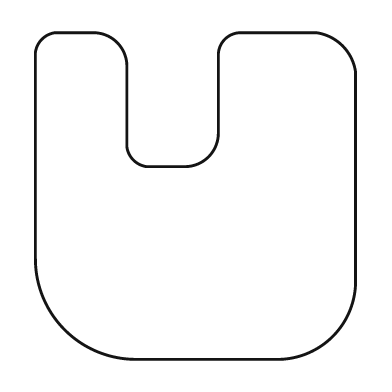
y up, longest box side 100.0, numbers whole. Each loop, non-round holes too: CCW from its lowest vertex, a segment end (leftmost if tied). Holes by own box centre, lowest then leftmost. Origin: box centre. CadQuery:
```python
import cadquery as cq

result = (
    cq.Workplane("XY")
    .moveTo(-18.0, -50.0)
    .lineTo(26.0, -50.0)
    .threePointArc((42.0, -43.0), (49.0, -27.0))
    .lineTo(49.0, 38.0)
    .threePointArc((45.0, 46.0), (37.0, 50.0))
    .lineTo(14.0, 50.0)
    .threePointArc((9.0, 48.0), (7.0, 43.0))
    .lineTo(7.0, 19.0)
    .threePointArc((4.0, 12.0), (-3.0, 9.0))
    .lineTo(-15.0, 9.0)
    .threePointArc((-19.0, 11.0), (-21.0, 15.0))
    .lineTo(-21.0, 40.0)
    .threePointArc((-24.0, 47.0), (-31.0, 50.0))
    .lineTo(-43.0, 50.0)
    .threePointArc((-47.0, 48.0), (-49.0, 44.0))
    .lineTo(-49.0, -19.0)
    .threePointArc((-40.0, -41.0), (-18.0, -50.0))
    .close()
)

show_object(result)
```